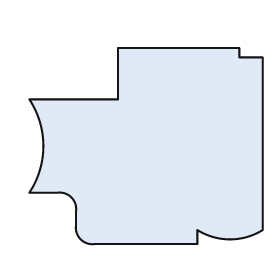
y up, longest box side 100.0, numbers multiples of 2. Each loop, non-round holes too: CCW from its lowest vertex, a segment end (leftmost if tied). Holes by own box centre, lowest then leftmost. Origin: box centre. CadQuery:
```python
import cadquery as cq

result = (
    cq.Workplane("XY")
    .moveTo(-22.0, -42.0)
    .lineTo(22.0, -42.0)
    .lineTo(22.0, -36.0)
    .threePointArc((36.0, -40.0), (50.0, -36.0))
    .lineTo(50.0, 38.0)
    .lineTo(40.0, 38.0)
    .lineTo(40.0, 42.0)
    .lineTo(-12.0, 42.0)
    .lineTo(-12.0, 20.0)
    .lineTo(-50.0, 20.0)
    .threePointArc((-44.0, 0.0), (-50.0, -20.0))
    .lineTo(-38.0, -20.0)
    .threePointArc((-32.0, -22.0), (-30.0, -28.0))
    .lineTo(-30.0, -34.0)
    .threePointArc((-28.0, -40.0), (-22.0, -42.0))
    .close()
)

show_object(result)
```